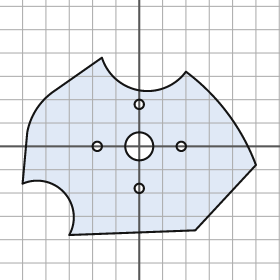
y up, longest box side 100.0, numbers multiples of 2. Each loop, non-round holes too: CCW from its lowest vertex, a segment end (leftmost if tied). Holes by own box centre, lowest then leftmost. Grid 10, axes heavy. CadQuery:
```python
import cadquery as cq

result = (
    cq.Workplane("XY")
    .moveTo(-30.0, -38.0)
    .lineTo(24.0, -36.0)
    .lineTo(50.0, -8.0)
    .threePointArc((38.0, 14.0), (20.0, 32.0))
    .threePointArc((0.0, 24.0), (-16.0, 38.0))
    .lineTo(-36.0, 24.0)
    .threePointArc((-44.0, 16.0), (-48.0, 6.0))
    .lineTo(-50.0, -16.0)
    .threePointArc((-32.0, -20.0), (-30.0, -38.0))
    .close()
    .moveTo(0.0, -18.0)
    .circle(2.0)
    .moveTo(-18.0, 0.0)
    .circle(2.0)
    .moveTo(0.0, 0.0)
    .circle(6.0)
    .moveTo(18.0, 0.0)
    .circle(2.0)
    .moveTo(0.0, 18.0)
    .circle(2.0)
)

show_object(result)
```